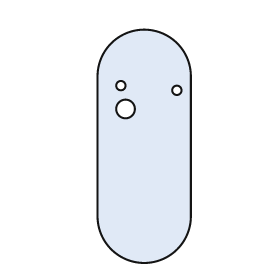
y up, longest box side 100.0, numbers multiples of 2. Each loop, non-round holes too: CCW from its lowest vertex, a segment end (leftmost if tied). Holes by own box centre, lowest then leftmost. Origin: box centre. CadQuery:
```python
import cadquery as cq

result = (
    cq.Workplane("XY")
    .moveTo(-20.0, -30.0)
    .threePointArc((0.0, -50.0), (20.0, -30.0))
    .lineTo(20.0, 30.0)
    .threePointArc((0.0, 50.0), (-20.0, 30.0))
    .close()
    .moveTo(-8.0, 16.0)
    .circle(4.0)
    .moveTo(14.0, 24.0)
    .circle(2.0)
    .moveTo(-10.0, 26.0)
    .circle(2.0)
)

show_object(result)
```